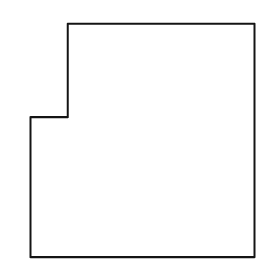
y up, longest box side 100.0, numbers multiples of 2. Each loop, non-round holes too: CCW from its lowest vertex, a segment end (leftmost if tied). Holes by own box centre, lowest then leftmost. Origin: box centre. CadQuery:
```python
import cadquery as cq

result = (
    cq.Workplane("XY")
    .moveTo(-48.0, -50.0)
    .lineTo(48.0, -50.0)
    .lineTo(48.0, 50.0)
    .lineTo(-32.0, 50.0)
    .lineTo(-32.0, 10.0)
    .lineTo(-48.0, 10.0)
    .close()
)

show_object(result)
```